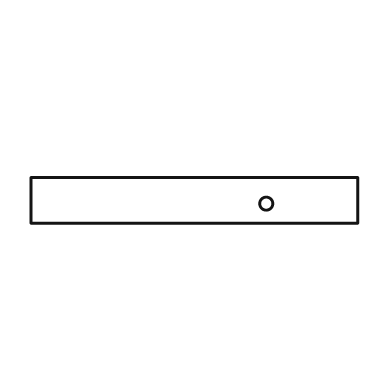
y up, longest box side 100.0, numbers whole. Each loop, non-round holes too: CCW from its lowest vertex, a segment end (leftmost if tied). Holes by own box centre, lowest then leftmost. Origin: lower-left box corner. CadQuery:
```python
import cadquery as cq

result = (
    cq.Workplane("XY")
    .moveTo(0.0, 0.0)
    .lineTo(100.0, 0.0)
    .lineTo(100.0, 14.0)
    .lineTo(0.0, 14.0)
    .close()
    .moveTo(72.0, 6.0)
    .circle(2.0)
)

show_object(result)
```